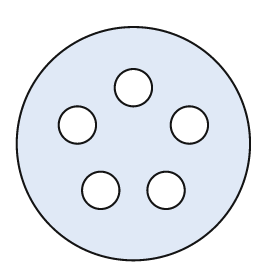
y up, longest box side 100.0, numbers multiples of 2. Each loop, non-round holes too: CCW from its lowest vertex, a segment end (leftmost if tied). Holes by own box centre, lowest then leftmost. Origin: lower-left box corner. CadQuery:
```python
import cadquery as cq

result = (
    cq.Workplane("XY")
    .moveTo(50.0, 50.0)
    .circle(50.0)
    .moveTo(36.0, 30.0)
    .circle(8.0)
    .moveTo(64.0, 30.0)
    .circle(8.0)
    .moveTo(26.0, 58.0)
    .circle(8.0)
    .moveTo(74.0, 58.0)
    .circle(8.0)
    .moveTo(50.0, 74.0)
    .circle(8.0)
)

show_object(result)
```